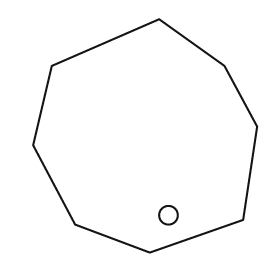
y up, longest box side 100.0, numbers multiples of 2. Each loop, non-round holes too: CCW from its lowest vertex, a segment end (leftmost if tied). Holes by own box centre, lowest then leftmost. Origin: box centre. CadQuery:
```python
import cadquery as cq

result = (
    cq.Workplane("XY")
    .moveTo(2.0, -50.0)
    .lineTo(42.0, -36.0)
    .lineTo(48.0, 4.0)
    .lineTo(34.0, 30.0)
    .lineTo(6.0, 50.0)
    .lineTo(-40.0, 30.0)
    .lineTo(-48.0, -4.0)
    .lineTo(-30.0, -38.0)
    .close()
    .moveTo(10.0, -34.0)
    .circle(4.0)
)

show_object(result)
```